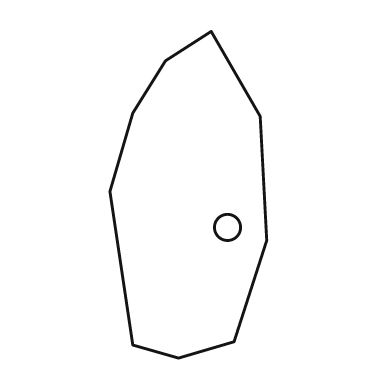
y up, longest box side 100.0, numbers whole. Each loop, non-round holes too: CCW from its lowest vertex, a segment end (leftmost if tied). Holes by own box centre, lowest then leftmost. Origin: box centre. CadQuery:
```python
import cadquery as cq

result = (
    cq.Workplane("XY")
    .moveTo(-3.0, -50.0)
    .lineTo(14.0, -45.0)
    .lineTo(24.0, -14.0)
    .lineTo(22.0, 24.0)
    .lineTo(7.0, 50.0)
    .lineTo(-7.0, 41.0)
    .lineTo(-17.0, 25.0)
    .lineTo(-24.0, 1.0)
    .lineTo(-17.0, -46.0)
    .close()
    .moveTo(12.0, -10.0)
    .circle(4.0)
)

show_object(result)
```